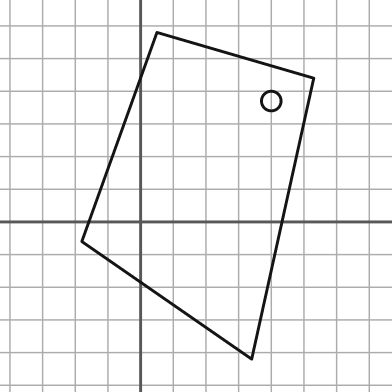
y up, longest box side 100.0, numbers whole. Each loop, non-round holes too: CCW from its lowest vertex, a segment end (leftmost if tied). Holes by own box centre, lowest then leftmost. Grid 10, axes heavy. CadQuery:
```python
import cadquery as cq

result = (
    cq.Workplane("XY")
    .moveTo(34.0, -42.0)
    .lineTo(53.0, 44.0)
    .lineTo(5.0, 58.0)
    .lineTo(-18.0, -6.0)
    .close()
    .moveTo(40.0, 37.0)
    .circle(3.0)
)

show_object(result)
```